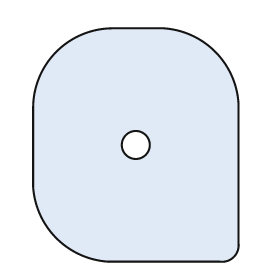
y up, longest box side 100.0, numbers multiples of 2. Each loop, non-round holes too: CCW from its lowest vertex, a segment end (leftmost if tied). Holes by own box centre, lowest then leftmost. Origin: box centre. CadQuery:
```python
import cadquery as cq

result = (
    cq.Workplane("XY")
    .moveTo(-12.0, -50.0)
    .lineTo(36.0, -50.0)
    .threePointArc((42.0, -48.0), (44.0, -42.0))
    .lineTo(44.0, 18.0)
    .threePointArc((34.0, 40.0), (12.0, 50.0))
    .lineTo(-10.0, 50.0)
    .threePointArc((-34.0, 40.0), (-44.0, 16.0))
    .lineTo(-44.0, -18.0)
    .threePointArc((-34.0, -40.0), (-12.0, -50.0))
    .close()
    .moveTo(0.0, 0.0)
    .circle(6.0)
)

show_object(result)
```